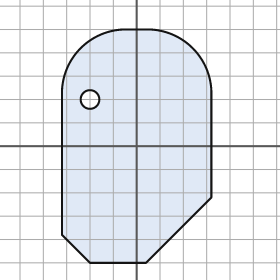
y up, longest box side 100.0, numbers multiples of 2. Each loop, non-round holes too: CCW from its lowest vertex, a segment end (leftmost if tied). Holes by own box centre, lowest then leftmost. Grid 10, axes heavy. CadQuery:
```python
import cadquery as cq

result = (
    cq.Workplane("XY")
    .moveTo(-20.0, -50.0)
    .lineTo(4.0, -50.0)
    .lineTo(32.0, -22.0)
    .lineTo(32.0, 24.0)
    .threePointArc((24.0, 42.0), (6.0, 50.0))
    .lineTo(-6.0, 50.0)
    .threePointArc((-24.0, 42.0), (-32.0, 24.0))
    .lineTo(-32.0, -38.0)
    .close()
    .moveTo(-20.0, 20.0)
    .circle(4.0)
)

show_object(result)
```